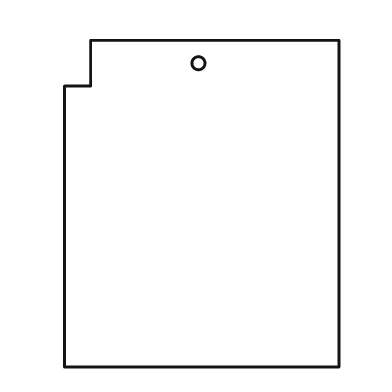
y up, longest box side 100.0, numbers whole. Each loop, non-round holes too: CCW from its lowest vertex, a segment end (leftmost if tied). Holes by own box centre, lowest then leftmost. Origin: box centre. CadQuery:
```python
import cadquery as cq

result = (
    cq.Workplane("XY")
    .moveTo(-42.0, -50.0)
    .lineTo(42.0, -50.0)
    .lineTo(42.0, 50.0)
    .lineTo(-34.0, 50.0)
    .lineTo(-34.0, 36.0)
    .lineTo(-42.0, 36.0)
    .close()
    .moveTo(-1.0, 43.0)
    .circle(2.0)
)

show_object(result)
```